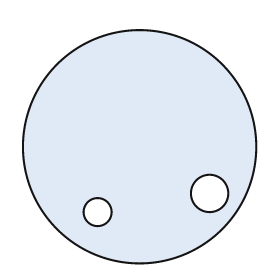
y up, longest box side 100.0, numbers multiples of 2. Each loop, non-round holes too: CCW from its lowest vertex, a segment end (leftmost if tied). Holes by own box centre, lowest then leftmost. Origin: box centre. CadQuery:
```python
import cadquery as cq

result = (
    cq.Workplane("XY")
    .moveTo(0.0, 0.0)
    .circle(50.0)
    .moveTo(-18.0, -28.0)
    .circle(6.0)
    .moveTo(30.0, -20.0)
    .circle(8.0)
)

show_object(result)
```